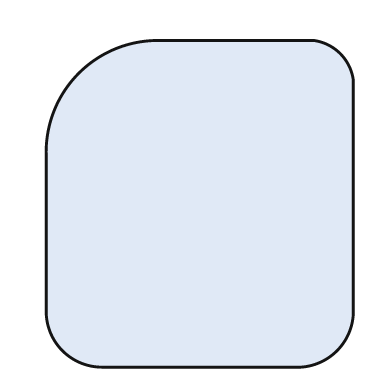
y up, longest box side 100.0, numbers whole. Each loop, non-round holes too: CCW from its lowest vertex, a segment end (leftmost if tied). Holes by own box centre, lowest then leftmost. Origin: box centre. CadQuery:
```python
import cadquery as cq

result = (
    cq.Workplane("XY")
    .moveTo(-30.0, -50.0)
    .lineTo(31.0, -50.0)
    .threePointArc((42.0, -45.0), (47.0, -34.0))
    .lineTo(47.0, 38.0)
    .threePointArc((43.0, 46.0), (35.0, 50.0))
    .lineTo(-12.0, 50.0)
    .threePointArc((-37.0, 40.0), (-47.0, 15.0))
    .lineTo(-47.0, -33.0)
    .threePointArc((-42.0, -45.0), (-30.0, -50.0))
    .close()
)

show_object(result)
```